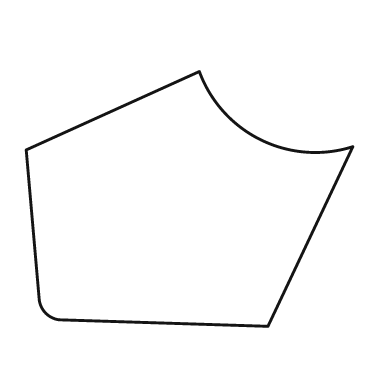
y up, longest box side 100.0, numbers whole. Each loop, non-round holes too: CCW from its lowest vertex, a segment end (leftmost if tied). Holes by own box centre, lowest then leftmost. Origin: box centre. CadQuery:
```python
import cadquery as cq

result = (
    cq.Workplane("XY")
    .moveTo(24.0, -39.0)
    .lineTo(50.0, 16.0)
    .threePointArc((22.0, 18.0), (3.0, 39.0))
    .lineTo(-50.0, 15.0)
    .lineTo(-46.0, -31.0)
    .threePointArc((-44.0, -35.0), (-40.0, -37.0))
    .close()
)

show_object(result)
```